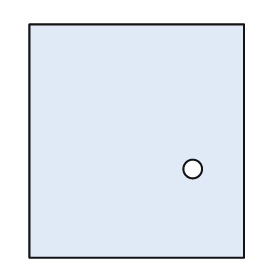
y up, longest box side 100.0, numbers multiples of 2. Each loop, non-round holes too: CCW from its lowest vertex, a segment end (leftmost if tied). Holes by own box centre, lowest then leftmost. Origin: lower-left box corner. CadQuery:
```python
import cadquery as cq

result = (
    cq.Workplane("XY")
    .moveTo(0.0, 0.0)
    .lineTo(92.0, 0.0)
    .lineTo(92.0, 100.0)
    .lineTo(0.0, 100.0)
    .close()
    .moveTo(70.0, 38.0)
    .circle(4.0)
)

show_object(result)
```